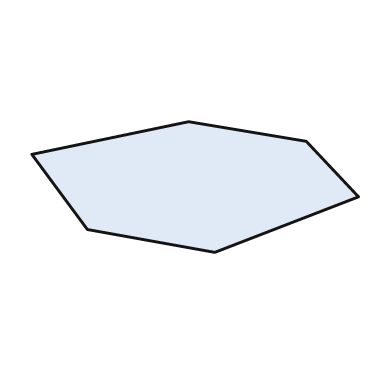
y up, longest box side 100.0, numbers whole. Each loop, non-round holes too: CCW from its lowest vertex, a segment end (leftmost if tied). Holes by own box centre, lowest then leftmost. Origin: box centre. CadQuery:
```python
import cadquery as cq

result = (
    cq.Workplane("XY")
    .moveTo(6.0, -20.0)
    .lineTo(50.0, -3.0)
    .lineTo(34.0, 14.0)
    .lineTo(-2.0, 20.0)
    .lineTo(-50.0, 10.0)
    .lineTo(-33.0, -13.0)
    .close()
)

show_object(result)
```